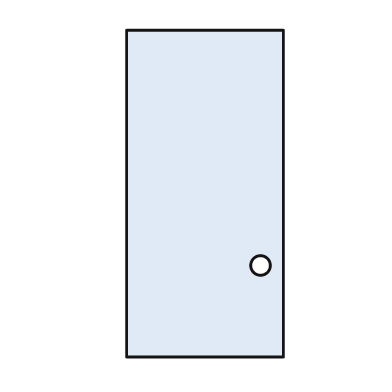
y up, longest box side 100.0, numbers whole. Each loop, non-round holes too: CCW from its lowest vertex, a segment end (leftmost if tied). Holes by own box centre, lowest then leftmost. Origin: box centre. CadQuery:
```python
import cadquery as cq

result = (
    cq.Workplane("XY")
    .moveTo(-24.0, -50.0)
    .lineTo(24.0, -50.0)
    .lineTo(24.0, 50.0)
    .lineTo(-24.0, 50.0)
    .close()
    .moveTo(17.0, -22.0)
    .circle(3.0)
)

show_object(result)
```